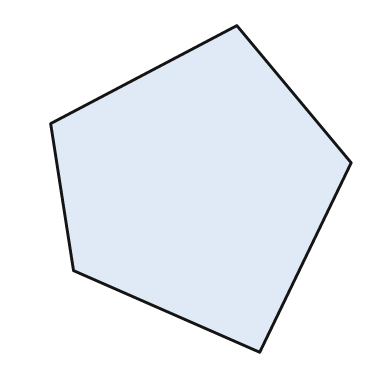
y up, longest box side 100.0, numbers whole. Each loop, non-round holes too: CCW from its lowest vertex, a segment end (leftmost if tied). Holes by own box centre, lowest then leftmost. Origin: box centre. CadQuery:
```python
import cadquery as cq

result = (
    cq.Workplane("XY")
    .moveTo(18.0, -50.0)
    .lineTo(46.0, 8.0)
    .lineTo(11.0, 50.0)
    .lineTo(-46.0, 20.0)
    .lineTo(-39.0, -25.0)
    .close()
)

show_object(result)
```